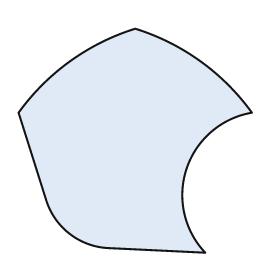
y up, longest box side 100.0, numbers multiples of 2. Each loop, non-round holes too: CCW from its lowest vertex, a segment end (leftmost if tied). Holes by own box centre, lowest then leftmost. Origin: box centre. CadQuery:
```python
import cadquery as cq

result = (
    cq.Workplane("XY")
    .moveTo(30.0, -48.0)
    .threePointArc((22.0, -12.0), (50.0, 12.0))
    .threePointArc((28.0, 34.0), (0.0, 48.0))
    .threePointArc((-28.0, 34.0), (-50.0, 12.0))
    .lineTo(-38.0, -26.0)
    .threePointArc((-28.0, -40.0), (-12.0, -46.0))
    .close()
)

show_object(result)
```